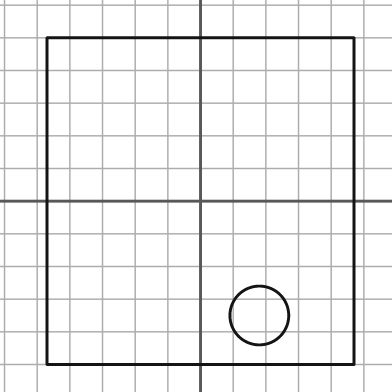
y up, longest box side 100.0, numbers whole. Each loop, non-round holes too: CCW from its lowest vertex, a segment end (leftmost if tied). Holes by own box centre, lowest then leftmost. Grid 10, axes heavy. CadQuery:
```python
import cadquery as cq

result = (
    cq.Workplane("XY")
    .moveTo(-47.0, -50.0)
    .lineTo(47.0, -50.0)
    .lineTo(47.0, 50.0)
    .lineTo(-47.0, 50.0)
    .close()
    .moveTo(18.0, -35.0)
    .circle(9.0)
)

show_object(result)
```